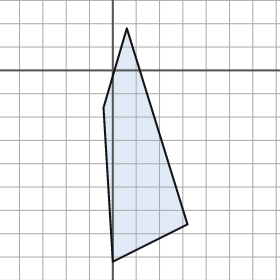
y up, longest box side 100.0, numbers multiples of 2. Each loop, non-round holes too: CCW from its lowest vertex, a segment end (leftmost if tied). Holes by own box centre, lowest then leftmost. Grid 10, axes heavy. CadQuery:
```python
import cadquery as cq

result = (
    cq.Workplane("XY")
    .moveTo(0.0, -82.0)
    .lineTo(32.0, -66.0)
    .lineTo(6.0, 18.0)
    .lineTo(-4.0, -16.0)
    .close()
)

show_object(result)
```